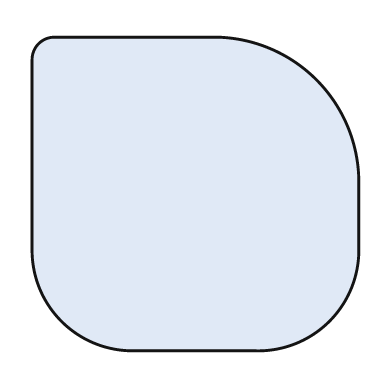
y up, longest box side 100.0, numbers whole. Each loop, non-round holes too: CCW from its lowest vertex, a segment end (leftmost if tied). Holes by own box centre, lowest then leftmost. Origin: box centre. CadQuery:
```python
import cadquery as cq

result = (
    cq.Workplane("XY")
    .moveTo(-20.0, -48.0)
    .lineTo(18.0, -48.0)
    .threePointArc((41.0, -39.0), (50.0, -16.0))
    .lineTo(50.0, 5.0)
    .threePointArc((37.0, 35.0), (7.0, 48.0))
    .lineTo(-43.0, 48.0)
    .threePointArc((-48.0, 46.0), (-50.0, 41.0))
    .lineTo(-50.0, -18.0)
    .threePointArc((-41.0, -39.0), (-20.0, -48.0))
    .close()
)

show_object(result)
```